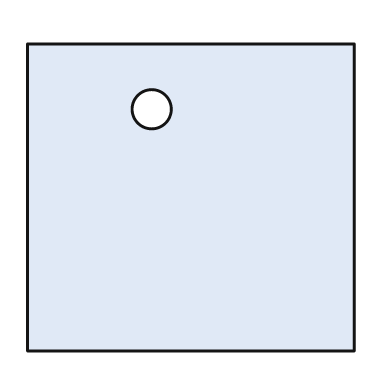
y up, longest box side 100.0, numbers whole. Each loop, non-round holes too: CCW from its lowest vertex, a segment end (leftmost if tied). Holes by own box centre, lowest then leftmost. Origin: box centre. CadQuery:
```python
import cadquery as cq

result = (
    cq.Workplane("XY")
    .moveTo(-50.0, -47.0)
    .lineTo(50.0, -47.0)
    .lineTo(50.0, 47.0)
    .lineTo(-50.0, 47.0)
    .close()
    .moveTo(-12.0, 27.0)
    .circle(6.0)
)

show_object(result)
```